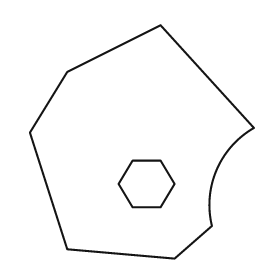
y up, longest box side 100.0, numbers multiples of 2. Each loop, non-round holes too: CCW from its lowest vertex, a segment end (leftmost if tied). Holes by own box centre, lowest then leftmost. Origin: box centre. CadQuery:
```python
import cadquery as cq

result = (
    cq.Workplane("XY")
    .moveTo(14.0, -50.0)
    .lineTo(30.0, -36.0)
    .threePointArc((32.0, -12.0), (48.0, 6.0))
    .lineTo(8.0, 50.0)
    .lineTo(-32.0, 30.0)
    .lineTo(-48.0, 4.0)
    .lineTo(-32.0, -46.0)
    .close()
    .moveTo(-4.0, -28.0)
    .lineTo(8.0, -28.0)
    .lineTo(14.0, -18.0)
    .lineTo(8.0, -8.0)
    .lineTo(-4.0, -8.0)
    .lineTo(-10.0, -18.0)
    .close()
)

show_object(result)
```